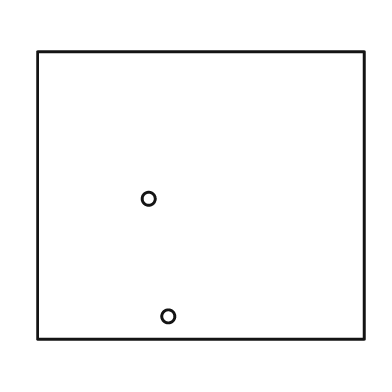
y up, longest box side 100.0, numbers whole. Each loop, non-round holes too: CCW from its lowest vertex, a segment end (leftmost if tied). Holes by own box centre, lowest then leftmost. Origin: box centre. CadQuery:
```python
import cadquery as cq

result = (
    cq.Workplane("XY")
    .moveTo(-50.0, -44.0)
    .lineTo(50.0, -44.0)
    .lineTo(50.0, 44.0)
    .lineTo(-50.0, 44.0)
    .close()
    .moveTo(-10.0, -37.0)
    .circle(2.0)
    .moveTo(-16.0, -1.0)
    .circle(2.0)
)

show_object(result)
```